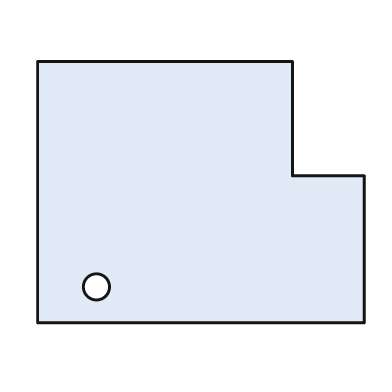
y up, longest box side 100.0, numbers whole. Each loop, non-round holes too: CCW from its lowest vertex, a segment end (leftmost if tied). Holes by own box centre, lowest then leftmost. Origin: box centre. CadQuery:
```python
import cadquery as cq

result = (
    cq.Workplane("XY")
    .moveTo(-50.0, -40.0)
    .lineTo(50.0, -40.0)
    .lineTo(50.0, 5.0)
    .lineTo(28.0, 5.0)
    .lineTo(28.0, 40.0)
    .lineTo(-50.0, 40.0)
    .close()
    .moveTo(-32.0, -29.0)
    .circle(4.0)
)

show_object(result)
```